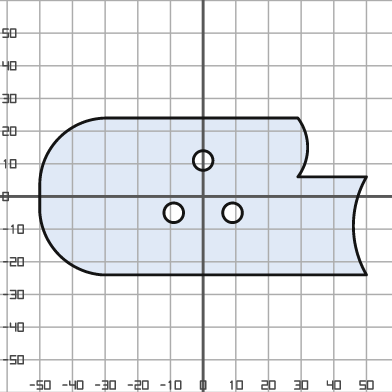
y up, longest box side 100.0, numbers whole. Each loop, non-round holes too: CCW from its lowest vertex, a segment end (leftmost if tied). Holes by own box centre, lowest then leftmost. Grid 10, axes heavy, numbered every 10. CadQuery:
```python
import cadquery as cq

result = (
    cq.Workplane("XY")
    .moveTo(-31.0, -24.0)
    .lineTo(50.0, -24.0)
    .threePointArc((46.0, -9.0), (50.0, 6.0))
    .lineTo(29.0, 6.0)
    .threePointArc((32.0, 15.0), (29.0, 24.0))
    .lineTo(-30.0, 24.0)
    .threePointArc((-44.0, 18.0), (-50.0, 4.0))
    .lineTo(-50.0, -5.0)
    .threePointArc((-44.0, -18.0), (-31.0, -24.0))
    .close()
    .moveTo(-9.0, -5.0)
    .circle(3.0)
    .moveTo(9.0, -5.0)
    .circle(3.0)
    .moveTo(0.0, 11.0)
    .circle(3.0)
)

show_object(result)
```